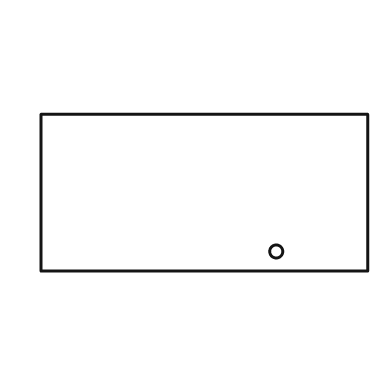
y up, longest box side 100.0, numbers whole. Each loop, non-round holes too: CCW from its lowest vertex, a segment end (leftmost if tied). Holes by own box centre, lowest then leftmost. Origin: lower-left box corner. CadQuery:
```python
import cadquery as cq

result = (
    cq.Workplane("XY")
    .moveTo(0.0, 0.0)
    .lineTo(100.0, 0.0)
    .lineTo(100.0, 48.0)
    .lineTo(0.0, 48.0)
    .close()
    .moveTo(72.0, 6.0)
    .circle(2.0)
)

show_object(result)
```